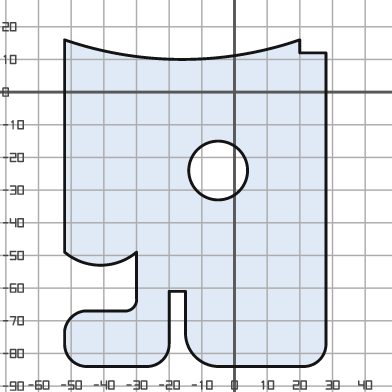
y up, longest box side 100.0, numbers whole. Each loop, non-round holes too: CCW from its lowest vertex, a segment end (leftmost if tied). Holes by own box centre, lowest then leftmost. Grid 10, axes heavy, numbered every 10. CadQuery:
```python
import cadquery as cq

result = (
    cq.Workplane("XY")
    .moveTo(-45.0, -84.0)
    .lineTo(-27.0, -84.0)
    .threePointArc((-22.0, -82.0), (-20.0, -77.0))
    .lineTo(-20.0, -61.0)
    .lineTo(-15.0, -61.0)
    .lineTo(-15.0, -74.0)
    .threePointArc((-12.0, -81.0), (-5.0, -84.0))
    .lineTo(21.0, -84.0)
    .threePointArc((26.0, -82.0), (28.0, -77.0))
    .lineTo(28.0, 12.0)
    .lineTo(20.0, 12.0)
    .lineTo(20.0, 16.0)
    .threePointArc((-16.0, 10.0), (-52.0, 16.0))
    .lineTo(-52.0, -49.0)
    .threePointArc((-41.0, -53.0), (-30.0, -49.0))
    .lineTo(-30.0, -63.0)
    .threePointArc((-31.0, -66.0), (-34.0, -67.0))
    .lineTo(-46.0, -67.0)
    .threePointArc((-50.0, -69.0), (-52.0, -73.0))
    .lineTo(-52.0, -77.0)
    .threePointArc((-50.0, -82.0), (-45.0, -84.0))
    .close()
    .moveTo(-5.0, -24.0)
    .circle(9.0)
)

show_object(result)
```